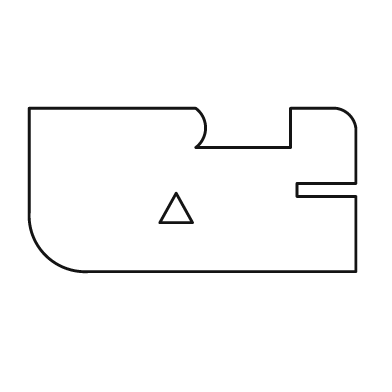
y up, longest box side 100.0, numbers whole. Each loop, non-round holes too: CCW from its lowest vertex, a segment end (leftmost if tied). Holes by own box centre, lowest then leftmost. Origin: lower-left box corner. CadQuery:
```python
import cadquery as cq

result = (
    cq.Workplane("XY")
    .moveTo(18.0, 0.0)
    .lineTo(100.0, 0.0)
    .lineTo(100.0, 23.0)
    .lineTo(82.0, 23.0)
    .lineTo(82.0, 27.0)
    .lineTo(100.0, 27.0)
    .lineTo(100.0, 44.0)
    .threePointArc((98.0, 48.0), (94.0, 50.0))
    .lineTo(80.0, 50.0)
    .lineTo(80.0, 38.0)
    .lineTo(51.0, 38.0)
    .threePointArc((54.0, 44.0), (51.0, 50.0))
    .lineTo(0.0, 50.0)
    .lineTo(0.0, 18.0)
    .threePointArc((5.0, 5.0), (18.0, 0.0))
    .close()
    .moveTo(40.0, 15.0)
    .lineTo(50.0, 15.0)
    .lineTo(45.0, 24.0)
    .close()
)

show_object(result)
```